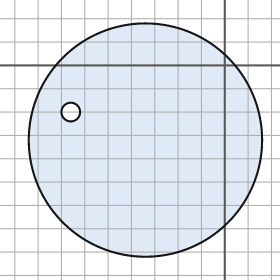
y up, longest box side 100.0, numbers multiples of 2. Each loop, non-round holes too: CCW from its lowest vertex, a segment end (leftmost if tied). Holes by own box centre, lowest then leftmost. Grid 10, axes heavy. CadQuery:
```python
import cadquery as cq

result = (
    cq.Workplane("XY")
    .moveTo(-34.0, -32.0)
    .circle(50.0)
    .moveTo(-66.0, -20.0)
    .circle(4.0)
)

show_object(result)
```